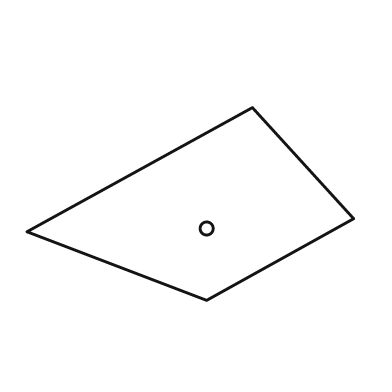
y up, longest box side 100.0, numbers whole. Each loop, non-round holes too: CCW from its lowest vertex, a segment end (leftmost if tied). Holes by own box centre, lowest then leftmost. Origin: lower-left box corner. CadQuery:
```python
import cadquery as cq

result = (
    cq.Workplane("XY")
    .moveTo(55.0, 0.0)
    .lineTo(100.0, 25.0)
    .lineTo(69.0, 59.0)
    .lineTo(0.0, 21.0)
    .close()
    .moveTo(55.0, 22.0)
    .circle(2.0)
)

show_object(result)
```